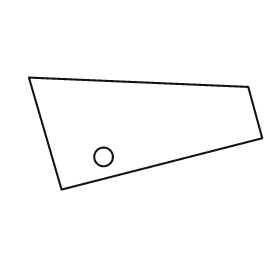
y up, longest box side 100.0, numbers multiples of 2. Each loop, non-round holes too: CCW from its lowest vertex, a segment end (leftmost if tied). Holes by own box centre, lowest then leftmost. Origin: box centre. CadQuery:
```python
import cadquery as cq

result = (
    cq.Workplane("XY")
    .moveTo(-36.0, -24.0)
    .lineTo(50.0, -2.0)
    .lineTo(44.0, 20.0)
    .lineTo(-50.0, 24.0)
    .close()
    .moveTo(-18.0, -10.0)
    .circle(4.0)
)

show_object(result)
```